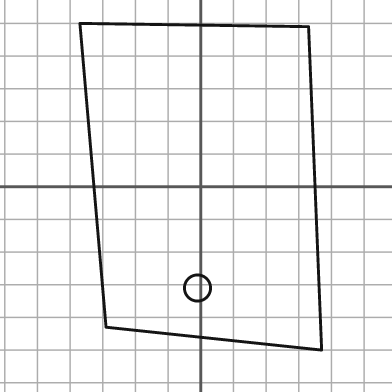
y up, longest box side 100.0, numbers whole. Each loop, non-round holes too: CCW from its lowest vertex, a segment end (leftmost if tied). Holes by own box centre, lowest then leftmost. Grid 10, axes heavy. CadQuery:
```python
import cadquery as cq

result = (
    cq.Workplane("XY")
    .moveTo(37.0, -50.0)
    .lineTo(33.0, 49.0)
    .lineTo(-37.0, 50.0)
    .lineTo(-29.0, -43.0)
    .close()
    .moveTo(-1.0, -31.0)
    .circle(4.0)
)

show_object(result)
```